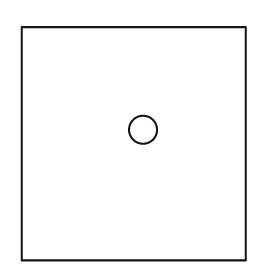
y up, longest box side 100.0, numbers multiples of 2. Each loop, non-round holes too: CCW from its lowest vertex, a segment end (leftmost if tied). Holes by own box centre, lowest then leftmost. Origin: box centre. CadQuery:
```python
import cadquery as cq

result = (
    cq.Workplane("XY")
    .moveTo(-48.0, -50.0)
    .lineTo(48.0, -50.0)
    .lineTo(48.0, 50.0)
    .lineTo(-48.0, 50.0)
    .close()
    .moveTo(4.0, 6.0)
    .circle(6.0)
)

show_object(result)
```